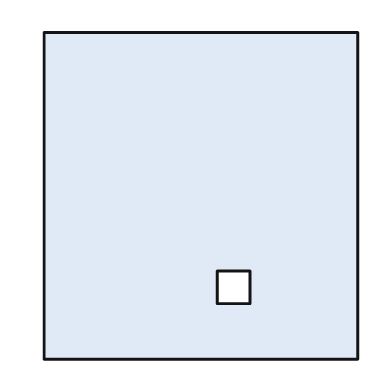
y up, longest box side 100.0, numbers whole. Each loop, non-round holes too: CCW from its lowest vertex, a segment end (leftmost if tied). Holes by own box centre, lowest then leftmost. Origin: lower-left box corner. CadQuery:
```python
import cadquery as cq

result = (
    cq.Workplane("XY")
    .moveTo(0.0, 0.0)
    .lineTo(96.0, 0.0)
    .lineTo(96.0, 100.0)
    .lineTo(0.0, 100.0)
    .close()
    .moveTo(53.0, 17.0)
    .lineTo(63.0, 17.0)
    .lineTo(63.0, 27.0)
    .lineTo(53.0, 27.0)
    .close()
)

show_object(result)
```